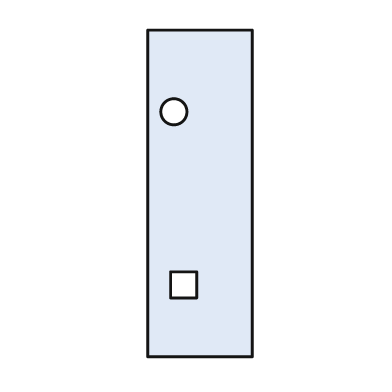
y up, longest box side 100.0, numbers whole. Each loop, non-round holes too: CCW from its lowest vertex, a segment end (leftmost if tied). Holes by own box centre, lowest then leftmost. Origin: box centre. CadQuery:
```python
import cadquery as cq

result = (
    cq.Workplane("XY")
    .moveTo(-16.0, -50.0)
    .lineTo(16.0, -50.0)
    .lineTo(16.0, 50.0)
    .lineTo(-16.0, 50.0)
    .close()
    .moveTo(-9.0, -32.0)
    .lineTo(-1.0, -32.0)
    .lineTo(-1.0, -24.0)
    .lineTo(-9.0, -24.0)
    .close()
    .moveTo(-8.0, 25.0)
    .circle(4.0)
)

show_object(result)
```